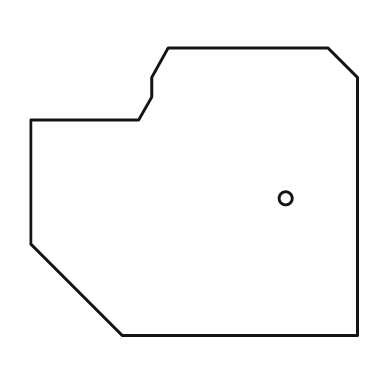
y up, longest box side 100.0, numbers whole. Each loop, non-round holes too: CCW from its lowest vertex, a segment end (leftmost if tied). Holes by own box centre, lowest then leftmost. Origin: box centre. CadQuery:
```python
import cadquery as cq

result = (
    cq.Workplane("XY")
    .moveTo(-22.0, -44.0)
    .lineTo(50.0, -44.0)
    .lineTo(50.0, 35.0)
    .lineTo(41.0, 44.0)
    .lineTo(-8.0, 44.0)
    .lineTo(-13.0, 35.0)
    .lineTo(-13.0, 29.0)
    .lineTo(-17.0, 22.0)
    .lineTo(-50.0, 22.0)
    .lineTo(-50.0, -16.0)
    .close()
    .moveTo(28.0, -2.0)
    .circle(2.0)
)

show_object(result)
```